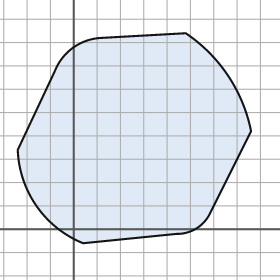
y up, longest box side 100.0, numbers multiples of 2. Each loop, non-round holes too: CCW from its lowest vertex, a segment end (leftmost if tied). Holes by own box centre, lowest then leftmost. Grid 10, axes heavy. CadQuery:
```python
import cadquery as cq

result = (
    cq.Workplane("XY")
    .moveTo(4.0, -6.0)
    .lineTo(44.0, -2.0)
    .threePointArc((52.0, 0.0), (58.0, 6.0))
    .lineTo(76.0, 42.0)
    .threePointArc((66.0, 66.0), (48.0, 84.0))
    .lineTo(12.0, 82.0)
    .threePointArc((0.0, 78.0), (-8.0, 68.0))
    .lineTo(-24.0, 34.0)
    .threePointArc((-16.0, 10.0), (4.0, -6.0))
    .close()
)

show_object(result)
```